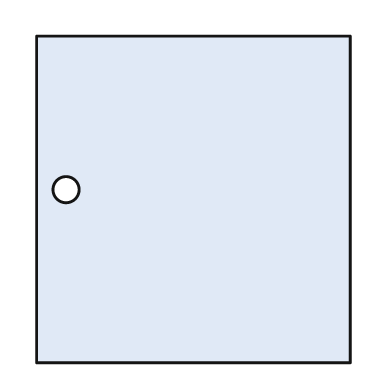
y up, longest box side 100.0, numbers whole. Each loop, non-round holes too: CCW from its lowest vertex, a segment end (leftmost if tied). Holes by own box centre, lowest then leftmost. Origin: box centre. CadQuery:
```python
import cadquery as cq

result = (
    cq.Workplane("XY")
    .moveTo(-48.0, -50.0)
    .lineTo(48.0, -50.0)
    .lineTo(48.0, 50.0)
    .lineTo(-48.0, 50.0)
    .close()
    .moveTo(-39.0, 3.0)
    .circle(4.0)
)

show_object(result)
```